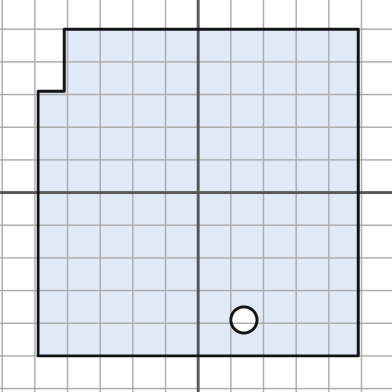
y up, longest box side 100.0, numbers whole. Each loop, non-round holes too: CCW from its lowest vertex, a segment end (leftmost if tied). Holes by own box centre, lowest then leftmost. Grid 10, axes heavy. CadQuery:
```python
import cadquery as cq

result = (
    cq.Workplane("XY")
    .moveTo(-49.0, -50.0)
    .lineTo(49.0, -50.0)
    .lineTo(49.0, 50.0)
    .lineTo(-41.0, 50.0)
    .lineTo(-41.0, 31.0)
    .lineTo(-49.0, 31.0)
    .close()
    .moveTo(14.0, -39.0)
    .circle(4.0)
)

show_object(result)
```